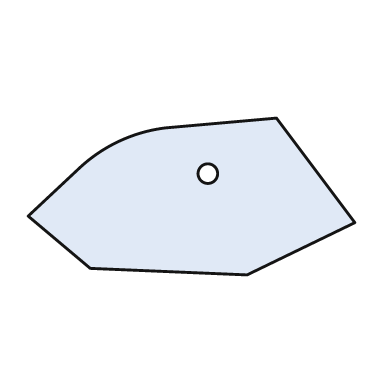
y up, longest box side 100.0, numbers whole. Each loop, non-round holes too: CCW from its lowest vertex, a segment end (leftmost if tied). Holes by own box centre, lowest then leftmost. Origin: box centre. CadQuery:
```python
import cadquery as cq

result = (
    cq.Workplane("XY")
    .moveTo(17.0, -24.0)
    .lineTo(50.0, -8.0)
    .lineTo(26.0, 24.0)
    .lineTo(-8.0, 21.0)
    .threePointArc((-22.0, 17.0), (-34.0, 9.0))
    .lineTo(-50.0, -6.0)
    .lineTo(-31.0, -22.0)
    .close()
    .moveTo(5.0, 7.0)
    .circle(3.0)
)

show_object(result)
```